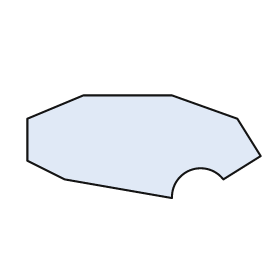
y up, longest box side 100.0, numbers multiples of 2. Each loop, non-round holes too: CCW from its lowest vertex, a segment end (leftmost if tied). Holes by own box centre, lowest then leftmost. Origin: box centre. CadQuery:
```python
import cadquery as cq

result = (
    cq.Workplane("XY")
    .moveTo(12.0, -22.0)
    .threePointArc((20.0, -10.0), (34.0, -14.0))
    .lineTo(50.0, -4.0)
    .lineTo(40.0, 12.0)
    .lineTo(12.0, 22.0)
    .lineTo(-26.0, 22.0)
    .lineTo(-50.0, 12.0)
    .lineTo(-50.0, -6.0)
    .lineTo(-34.0, -14.0)
    .close()
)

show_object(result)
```